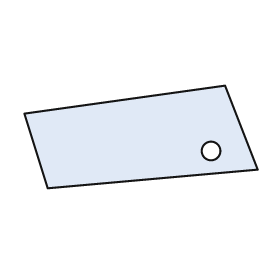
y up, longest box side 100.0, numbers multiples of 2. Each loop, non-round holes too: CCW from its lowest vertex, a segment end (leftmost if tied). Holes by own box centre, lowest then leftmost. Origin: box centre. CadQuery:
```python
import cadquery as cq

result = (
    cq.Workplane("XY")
    .moveTo(-40.0, -22.0)
    .lineTo(50.0, -14.0)
    .lineTo(36.0, 22.0)
    .lineTo(-50.0, 10.0)
    .close()
    .moveTo(30.0, -6.0)
    .circle(4.0)
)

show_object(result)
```